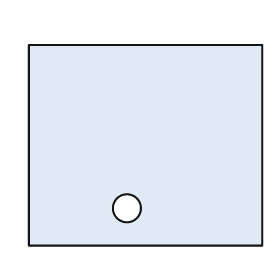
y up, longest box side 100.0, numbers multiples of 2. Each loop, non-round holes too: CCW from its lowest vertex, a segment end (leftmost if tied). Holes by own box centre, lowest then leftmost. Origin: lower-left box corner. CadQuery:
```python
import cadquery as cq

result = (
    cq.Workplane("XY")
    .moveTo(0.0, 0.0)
    .lineTo(100.0, 0.0)
    .lineTo(100.0, 86.0)
    .lineTo(0.0, 86.0)
    .close()
    .moveTo(42.0, 16.0)
    .circle(6.0)
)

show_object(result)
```